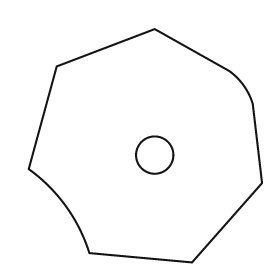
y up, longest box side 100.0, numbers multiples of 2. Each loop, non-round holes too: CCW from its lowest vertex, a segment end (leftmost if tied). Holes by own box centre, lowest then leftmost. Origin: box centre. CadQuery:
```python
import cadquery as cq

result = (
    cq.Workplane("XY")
    .moveTo(20.0, -50.0)
    .lineTo(50.0, -16.0)
    .lineTo(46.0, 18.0)
    .threePointArc((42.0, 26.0), (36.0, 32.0))
    .lineTo(4.0, 50.0)
    .lineTo(-38.0, 34.0)
    .lineTo(-50.0, -10.0)
    .threePointArc((-34.0, -26.0), (-24.0, -46.0))
    .close()
    .moveTo(4.0, -4.0)
    .circle(8.0)
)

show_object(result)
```